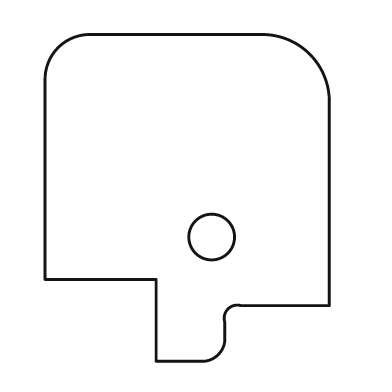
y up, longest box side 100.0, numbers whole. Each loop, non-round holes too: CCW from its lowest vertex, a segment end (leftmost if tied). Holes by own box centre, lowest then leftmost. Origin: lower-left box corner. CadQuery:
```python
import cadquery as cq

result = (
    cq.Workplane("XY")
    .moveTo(34.0, 0.0)
    .lineTo(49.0, 0.0)
    .threePointArc((53.0, 2.0), (55.0, 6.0))
    .lineTo(55.0, 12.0)
    .threePointArc((56.0, 16.0), (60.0, 17.0))
    .lineTo(87.0, 17.0)
    .lineTo(87.0, 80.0)
    .threePointArc((81.0, 94.0), (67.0, 100.0))
    .lineTo(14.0, 100.0)
    .threePointArc((4.0, 96.0), (0.0, 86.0))
    .lineTo(0.0, 25.0)
    .lineTo(34.0, 25.0)
    .close()
    .moveTo(51.0, 38.0)
    .circle(7.0)
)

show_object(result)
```